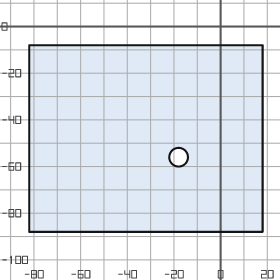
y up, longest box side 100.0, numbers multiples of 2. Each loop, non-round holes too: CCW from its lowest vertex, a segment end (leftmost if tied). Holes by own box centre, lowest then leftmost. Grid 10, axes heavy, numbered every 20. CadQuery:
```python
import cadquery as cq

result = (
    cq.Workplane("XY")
    .moveTo(-82.0, -88.0)
    .lineTo(18.0, -88.0)
    .lineTo(18.0, -8.0)
    .lineTo(-82.0, -8.0)
    .close()
    .moveTo(-18.0, -56.0)
    .circle(4.0)
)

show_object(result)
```